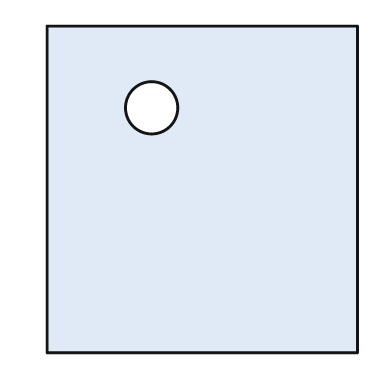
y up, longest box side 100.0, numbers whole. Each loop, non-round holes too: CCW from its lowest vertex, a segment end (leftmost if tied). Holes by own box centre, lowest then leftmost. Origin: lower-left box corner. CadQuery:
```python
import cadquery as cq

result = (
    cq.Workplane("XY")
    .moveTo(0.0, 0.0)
    .lineTo(95.0, 0.0)
    .lineTo(95.0, 100.0)
    .lineTo(0.0, 100.0)
    .close()
    .moveTo(32.0, 75.0)
    .circle(8.0)
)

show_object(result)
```